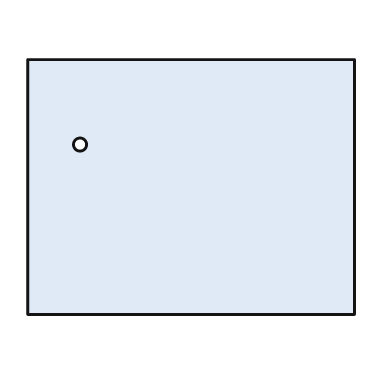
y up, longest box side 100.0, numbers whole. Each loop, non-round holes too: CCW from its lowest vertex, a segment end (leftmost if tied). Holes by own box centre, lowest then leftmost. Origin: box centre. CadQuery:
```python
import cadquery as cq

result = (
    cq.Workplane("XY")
    .moveTo(-50.0, -39.0)
    .lineTo(50.0, -39.0)
    .lineTo(50.0, 39.0)
    .lineTo(-50.0, 39.0)
    .close()
    .moveTo(-34.0, 13.0)
    .circle(2.0)
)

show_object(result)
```